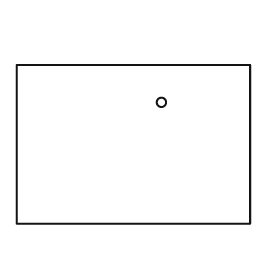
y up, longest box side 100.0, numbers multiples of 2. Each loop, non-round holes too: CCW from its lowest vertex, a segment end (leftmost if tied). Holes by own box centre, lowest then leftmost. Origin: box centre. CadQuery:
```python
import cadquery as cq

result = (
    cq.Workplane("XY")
    .moveTo(-50.0, -34.0)
    .lineTo(50.0, -34.0)
    .lineTo(50.0, 34.0)
    .lineTo(-50.0, 34.0)
    .close()
    .moveTo(12.0, 18.0)
    .circle(2.0)
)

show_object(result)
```